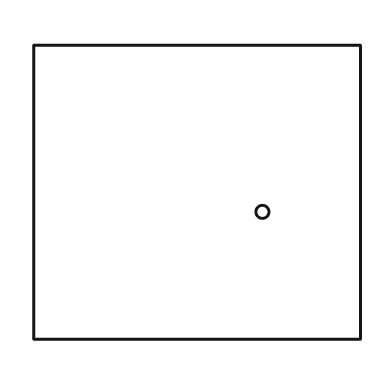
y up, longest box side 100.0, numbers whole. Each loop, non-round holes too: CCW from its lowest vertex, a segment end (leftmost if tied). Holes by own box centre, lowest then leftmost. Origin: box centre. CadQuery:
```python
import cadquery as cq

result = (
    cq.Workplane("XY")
    .moveTo(-50.0, -45.0)
    .lineTo(50.0, -45.0)
    .lineTo(50.0, 45.0)
    .lineTo(-50.0, 45.0)
    .close()
    .moveTo(20.0, -6.0)
    .circle(2.0)
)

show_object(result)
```